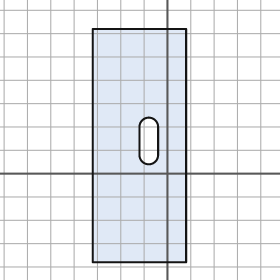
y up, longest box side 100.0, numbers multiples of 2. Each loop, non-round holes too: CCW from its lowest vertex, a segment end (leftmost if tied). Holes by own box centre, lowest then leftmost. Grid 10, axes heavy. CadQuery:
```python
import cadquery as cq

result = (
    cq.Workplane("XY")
    .moveTo(-32.0, -38.0)
    .lineTo(8.0, -38.0)
    .lineTo(8.0, 62.0)
    .lineTo(-32.0, 62.0)
    .close()
    .moveTo(-12.0, 8.0)
    .threePointArc((-8.0, 4.0), (-4.0, 8.0))
    .lineTo(-4.0, 20.0)
    .threePointArc((-8.0, 24.0), (-12.0, 20.0))
    .close()
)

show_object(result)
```